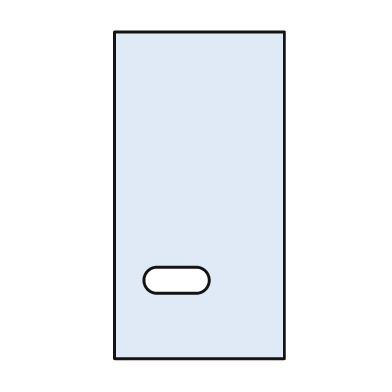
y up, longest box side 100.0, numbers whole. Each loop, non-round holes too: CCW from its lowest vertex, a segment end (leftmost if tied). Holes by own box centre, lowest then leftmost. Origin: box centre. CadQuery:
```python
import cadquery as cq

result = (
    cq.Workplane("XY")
    .moveTo(-26.0, -50.0)
    .lineTo(26.0, -50.0)
    .lineTo(26.0, 50.0)
    .lineTo(-26.0, 50.0)
    .close()
    .moveTo(-13.0, -30.0)
    .lineTo(-1.0, -30.0)
    .threePointArc((3.0, -26.0), (-1.0, -22.0))
    .lineTo(-13.0, -22.0)
    .threePointArc((-17.0, -26.0), (-13.0, -30.0))
    .close()
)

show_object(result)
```